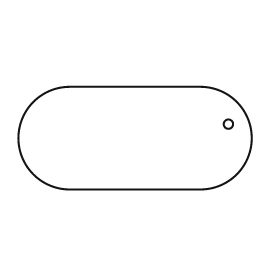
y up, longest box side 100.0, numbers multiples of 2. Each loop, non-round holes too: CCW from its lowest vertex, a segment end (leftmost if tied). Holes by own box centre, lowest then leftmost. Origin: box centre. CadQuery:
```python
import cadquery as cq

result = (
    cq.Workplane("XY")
    .moveTo(-28.0, -22.0)
    .lineTo(28.0, -22.0)
    .threePointArc((50.0, 0.0), (28.0, 22.0))
    .lineTo(-28.0, 22.0)
    .threePointArc((-50.0, 0.0), (-28.0, -22.0))
    .close()
    .moveTo(40.0, 6.0)
    .circle(2.0)
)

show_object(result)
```